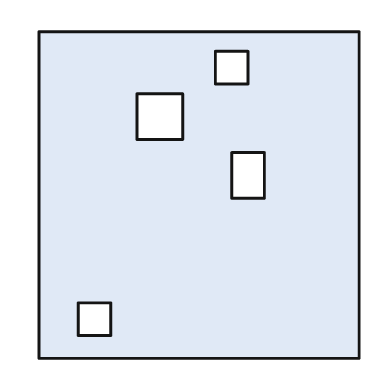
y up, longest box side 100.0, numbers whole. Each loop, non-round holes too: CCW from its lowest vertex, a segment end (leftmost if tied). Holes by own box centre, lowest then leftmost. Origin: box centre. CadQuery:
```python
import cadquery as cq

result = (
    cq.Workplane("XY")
    .moveTo(-49.0, -50.0)
    .lineTo(49.0, -50.0)
    .lineTo(49.0, 50.0)
    .lineTo(-49.0, 50.0)
    .close()
    .moveTo(-37.0, -43.0)
    .lineTo(-27.0, -43.0)
    .lineTo(-27.0, -33.0)
    .lineTo(-37.0, -33.0)
    .close()
    .moveTo(10.0, -1.0)
    .lineTo(20.0, -1.0)
    .lineTo(20.0, 13.0)
    .lineTo(10.0, 13.0)
    .close()
    .moveTo(-19.0, 17.0)
    .lineTo(-5.0, 17.0)
    .lineTo(-5.0, 31.0)
    .lineTo(-19.0, 31.0)
    .close()
    .moveTo(5.0, 34.0)
    .lineTo(15.0, 34.0)
    .lineTo(15.0, 44.0)
    .lineTo(5.0, 44.0)
    .close()
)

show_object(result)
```